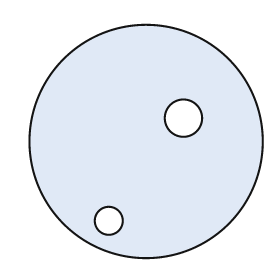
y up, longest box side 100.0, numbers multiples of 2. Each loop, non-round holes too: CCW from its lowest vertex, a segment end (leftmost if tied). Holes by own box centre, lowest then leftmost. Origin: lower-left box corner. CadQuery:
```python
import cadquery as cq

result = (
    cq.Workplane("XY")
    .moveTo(50.0, 50.0)
    .circle(50.0)
    .moveTo(34.0, 16.0)
    .circle(6.0)
    .moveTo(66.0, 60.0)
    .circle(8.0)
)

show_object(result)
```